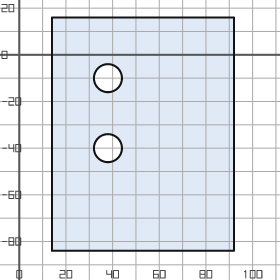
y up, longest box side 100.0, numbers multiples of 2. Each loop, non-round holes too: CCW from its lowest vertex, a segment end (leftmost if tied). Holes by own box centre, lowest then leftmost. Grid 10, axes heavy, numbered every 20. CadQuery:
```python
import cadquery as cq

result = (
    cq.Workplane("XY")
    .moveTo(14.0, -84.0)
    .lineTo(92.0, -84.0)
    .lineTo(92.0, 16.0)
    .lineTo(14.0, 16.0)
    .close()
    .moveTo(38.0, -40.0)
    .circle(6.0)
    .moveTo(38.0, -10.0)
    .circle(6.0)
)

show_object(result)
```